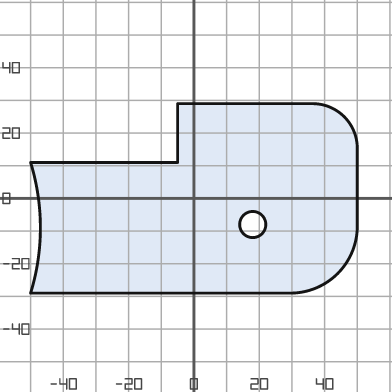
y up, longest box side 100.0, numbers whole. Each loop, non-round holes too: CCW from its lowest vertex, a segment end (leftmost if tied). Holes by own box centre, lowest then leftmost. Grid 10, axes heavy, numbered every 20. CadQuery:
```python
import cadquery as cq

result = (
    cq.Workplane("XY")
    .moveTo(-50.0, -29.0)
    .lineTo(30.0, -29.0)
    .threePointArc((44.0, -23.0), (50.0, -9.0))
    .lineTo(50.0, 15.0)
    .threePointArc((46.0, 25.0), (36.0, 29.0))
    .lineTo(-5.0, 29.0)
    .lineTo(-5.0, 11.0)
    .lineTo(-50.0, 11.0)
    .threePointArc((-47.0, -9.0), (-50.0, -29.0))
    .close()
    .moveTo(18.0, -8.0)
    .circle(4.0)
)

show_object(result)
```